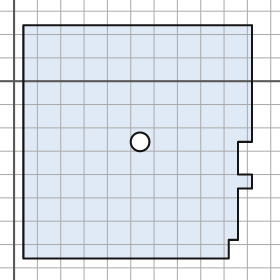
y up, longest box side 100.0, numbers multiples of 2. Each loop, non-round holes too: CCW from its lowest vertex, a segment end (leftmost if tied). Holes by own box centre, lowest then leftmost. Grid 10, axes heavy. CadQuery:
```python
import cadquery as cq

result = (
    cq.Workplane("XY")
    .moveTo(4.0, -76.0)
    .lineTo(92.0, -76.0)
    .lineTo(92.0, -68.0)
    .lineTo(96.0, -68.0)
    .lineTo(96.0, -46.0)
    .lineTo(102.0, -46.0)
    .lineTo(102.0, -40.0)
    .lineTo(96.0, -40.0)
    .lineTo(96.0, -26.0)
    .lineTo(102.0, -26.0)
    .lineTo(102.0, 24.0)
    .lineTo(4.0, 24.0)
    .close()
    .moveTo(54.0, -26.0)
    .circle(4.0)
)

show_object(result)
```